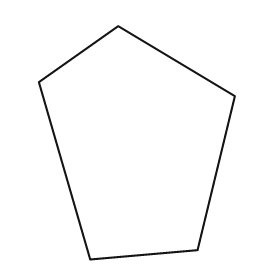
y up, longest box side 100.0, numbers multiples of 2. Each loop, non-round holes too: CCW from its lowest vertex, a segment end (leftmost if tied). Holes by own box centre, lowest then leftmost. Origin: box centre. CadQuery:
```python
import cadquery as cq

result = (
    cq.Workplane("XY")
    .moveTo(-20.0, -50.0)
    .lineTo(26.0, -46.0)
    .lineTo(42.0, 20.0)
    .lineTo(-8.0, 50.0)
    .lineTo(-42.0, 26.0)
    .close()
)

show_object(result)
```